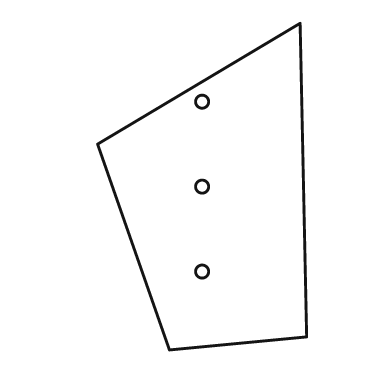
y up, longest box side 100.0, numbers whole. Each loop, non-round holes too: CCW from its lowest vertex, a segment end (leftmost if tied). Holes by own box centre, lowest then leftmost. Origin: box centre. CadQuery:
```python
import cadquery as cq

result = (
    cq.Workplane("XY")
    .moveTo(-10.0, -50.0)
    .lineTo(32.0, -46.0)
    .lineTo(30.0, 50.0)
    .lineTo(-32.0, 13.0)
    .close()
    .moveTo(0.0, -26.0)
    .circle(2.0)
    .moveTo(0.0, 0.0)
    .circle(2.0)
    .moveTo(0.0, 26.0)
    .circle(2.0)
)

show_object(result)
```